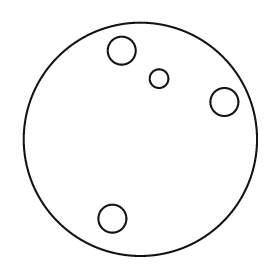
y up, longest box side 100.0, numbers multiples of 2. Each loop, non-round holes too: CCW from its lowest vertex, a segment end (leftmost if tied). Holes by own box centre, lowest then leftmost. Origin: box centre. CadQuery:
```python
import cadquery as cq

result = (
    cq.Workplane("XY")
    .moveTo(0.0, 0.0)
    .circle(50.0)
    .moveTo(-12.0, -34.0)
    .circle(6.0)
    .moveTo(36.0, 16.0)
    .circle(6.0)
    .moveTo(8.0, 26.0)
    .circle(4.0)
    .moveTo(-8.0, 38.0)
    .circle(6.0)
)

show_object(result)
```